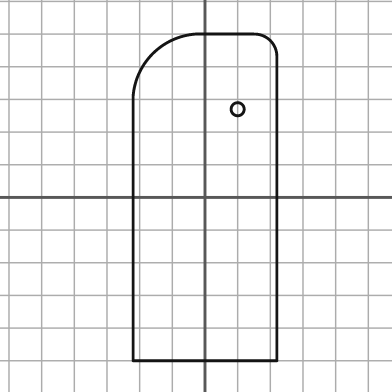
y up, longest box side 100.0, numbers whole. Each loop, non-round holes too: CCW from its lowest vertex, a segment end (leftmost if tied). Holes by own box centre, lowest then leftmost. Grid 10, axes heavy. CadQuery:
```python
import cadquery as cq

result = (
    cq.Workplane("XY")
    .moveTo(-22.0, -50.0)
    .lineTo(22.0, -50.0)
    .lineTo(22.0, 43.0)
    .threePointArc((20.0, 48.0), (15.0, 50.0))
    .lineTo(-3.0, 50.0)
    .threePointArc((-16.0, 44.0), (-22.0, 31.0))
    .close()
    .moveTo(10.0, 27.0)
    .circle(2.0)
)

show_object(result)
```